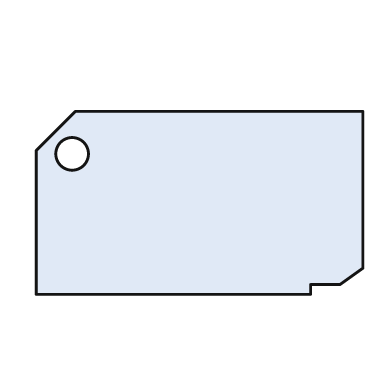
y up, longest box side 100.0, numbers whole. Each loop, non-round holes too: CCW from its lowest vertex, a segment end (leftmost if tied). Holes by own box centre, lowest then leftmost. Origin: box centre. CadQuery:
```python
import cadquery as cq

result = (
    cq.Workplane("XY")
    .moveTo(-50.0, -28.0)
    .lineTo(34.0, -28.0)
    .lineTo(34.0, -25.0)
    .lineTo(43.0, -25.0)
    .lineTo(50.0, -20.0)
    .lineTo(50.0, 28.0)
    .lineTo(-38.0, 28.0)
    .lineTo(-50.0, 16.0)
    .close()
    .moveTo(-39.0, 15.0)
    .circle(5.0)
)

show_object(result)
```